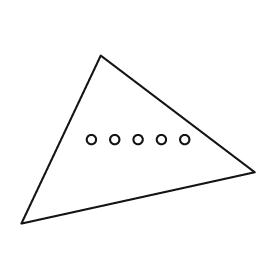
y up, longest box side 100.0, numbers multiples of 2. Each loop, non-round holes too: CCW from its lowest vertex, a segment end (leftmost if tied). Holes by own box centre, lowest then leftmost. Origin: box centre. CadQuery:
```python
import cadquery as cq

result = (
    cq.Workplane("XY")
    .moveTo(-50.0, -36.0)
    .lineTo(50.0, -14.0)
    .lineTo(-16.0, 36.0)
    .close()
    .moveTo(-20.0, 0.0)
    .circle(2.0)
    .moveTo(-10.0, 0.0)
    .circle(2.0)
    .moveTo(0.0, 0.0)
    .circle(2.0)
    .moveTo(10.0, 0.0)
    .circle(2.0)
    .moveTo(20.0, 0.0)
    .circle(2.0)
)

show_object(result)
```